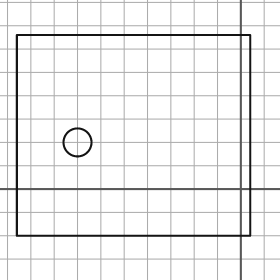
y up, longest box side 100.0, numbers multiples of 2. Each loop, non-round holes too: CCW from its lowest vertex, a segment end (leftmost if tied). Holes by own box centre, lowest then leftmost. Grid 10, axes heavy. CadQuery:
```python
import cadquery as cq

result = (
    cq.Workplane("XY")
    .moveTo(-96.0, -20.0)
    .lineTo(4.0, -20.0)
    .lineTo(4.0, 66.0)
    .lineTo(-96.0, 66.0)
    .close()
    .moveTo(-70.0, 20.0)
    .circle(6.0)
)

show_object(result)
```